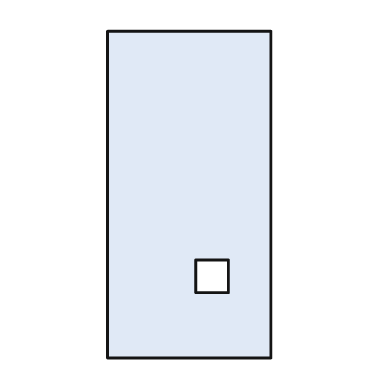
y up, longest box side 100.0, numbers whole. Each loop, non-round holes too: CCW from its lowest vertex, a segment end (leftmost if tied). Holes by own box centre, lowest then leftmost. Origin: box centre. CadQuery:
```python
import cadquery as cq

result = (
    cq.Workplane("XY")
    .moveTo(-25.0, -50.0)
    .lineTo(25.0, -50.0)
    .lineTo(25.0, 50.0)
    .lineTo(-25.0, 50.0)
    .close()
    .moveTo(2.0, -30.0)
    .lineTo(12.0, -30.0)
    .lineTo(12.0, -20.0)
    .lineTo(2.0, -20.0)
    .close()
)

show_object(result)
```